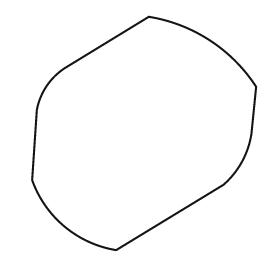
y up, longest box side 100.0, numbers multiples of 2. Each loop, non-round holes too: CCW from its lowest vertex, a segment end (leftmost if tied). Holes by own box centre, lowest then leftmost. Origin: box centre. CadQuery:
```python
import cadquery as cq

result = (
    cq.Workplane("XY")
    .moveTo(-12.0, -50.0)
    .lineTo(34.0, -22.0)
    .threePointArc((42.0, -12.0), (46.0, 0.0))
    .lineTo(48.0, 20.0)
    .threePointArc((28.0, 40.0), (2.0, 50.0))
    .lineTo(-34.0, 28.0)
    .threePointArc((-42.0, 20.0), (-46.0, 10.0))
    .lineTo(-48.0, -20.0)
    .threePointArc((-34.0, -40.0), (-12.0, -50.0))
    .close()
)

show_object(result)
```